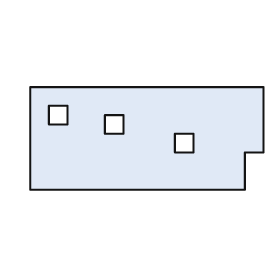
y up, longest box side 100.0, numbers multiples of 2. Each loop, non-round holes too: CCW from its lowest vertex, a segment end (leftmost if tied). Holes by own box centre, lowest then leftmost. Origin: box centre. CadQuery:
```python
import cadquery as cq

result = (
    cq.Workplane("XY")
    .moveTo(-50.0, -22.0)
    .lineTo(42.0, -22.0)
    .lineTo(42.0, -6.0)
    .lineTo(50.0, -6.0)
    .lineTo(50.0, 22.0)
    .lineTo(-50.0, 22.0)
    .close()
    .moveTo(12.0, -6.0)
    .lineTo(20.0, -6.0)
    .lineTo(20.0, 2.0)
    .lineTo(12.0, 2.0)
    .close()
    .moveTo(-18.0, 2.0)
    .lineTo(-10.0, 2.0)
    .lineTo(-10.0, 10.0)
    .lineTo(-18.0, 10.0)
    .close()
    .moveTo(-42.0, 6.0)
    .lineTo(-34.0, 6.0)
    .lineTo(-34.0, 14.0)
    .lineTo(-42.0, 14.0)
    .close()
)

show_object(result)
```